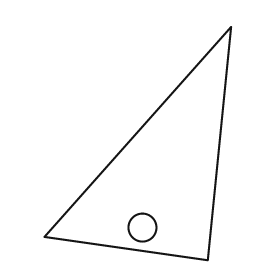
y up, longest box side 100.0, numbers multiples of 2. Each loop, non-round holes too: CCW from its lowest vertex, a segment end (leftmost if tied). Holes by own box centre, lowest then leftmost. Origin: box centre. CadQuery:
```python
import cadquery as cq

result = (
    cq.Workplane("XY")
    .moveTo(30.0, -50.0)
    .lineTo(40.0, 50.0)
    .lineTo(-40.0, -40.0)
    .close()
    .moveTo(2.0, -36.0)
    .circle(6.0)
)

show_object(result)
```